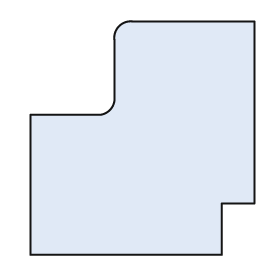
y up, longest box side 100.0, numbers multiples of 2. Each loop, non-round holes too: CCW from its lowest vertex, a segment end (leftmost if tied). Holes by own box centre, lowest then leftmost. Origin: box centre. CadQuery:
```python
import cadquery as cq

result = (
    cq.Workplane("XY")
    .moveTo(-48.0, -50.0)
    .lineTo(34.0, -50.0)
    .lineTo(34.0, -28.0)
    .lineTo(48.0, -28.0)
    .lineTo(48.0, 50.0)
    .lineTo(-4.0, 50.0)
    .threePointArc((-10.0, 48.0), (-12.0, 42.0))
    .lineTo(-12.0, 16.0)
    .threePointArc((-14.0, 12.0), (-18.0, 10.0))
    .lineTo(-48.0, 10.0)
    .close()
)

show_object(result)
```